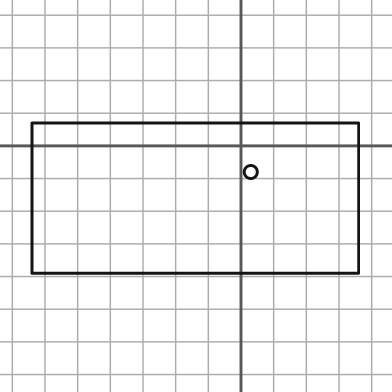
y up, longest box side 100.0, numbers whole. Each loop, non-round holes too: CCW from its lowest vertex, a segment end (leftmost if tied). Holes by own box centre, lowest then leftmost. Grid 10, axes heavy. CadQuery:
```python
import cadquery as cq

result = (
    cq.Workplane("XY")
    .moveTo(-64.0, -39.0)
    .lineTo(36.0, -39.0)
    .lineTo(36.0, 7.0)
    .lineTo(-64.0, 7.0)
    .close()
    .moveTo(3.0, -8.0)
    .circle(2.0)
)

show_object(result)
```